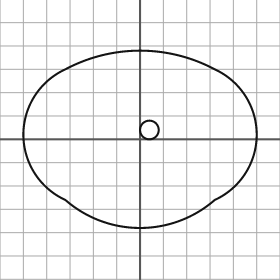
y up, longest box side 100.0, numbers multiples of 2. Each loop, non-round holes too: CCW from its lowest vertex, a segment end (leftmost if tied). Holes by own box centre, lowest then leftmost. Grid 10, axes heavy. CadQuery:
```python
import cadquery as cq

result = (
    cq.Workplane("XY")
    .moveTo(-32.0, -26.0)
    .threePointArc((0.0, -38.0), (32.0, -26.0))
    .threePointArc((50.0, 2.0), (32.0, 30.0))
    .threePointArc((0.0, 38.0), (-32.0, 30.0))
    .threePointArc((-50.0, 2.0), (-32.0, -26.0))
    .close()
    .moveTo(4.0, 4.0)
    .circle(4.0)
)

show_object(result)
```